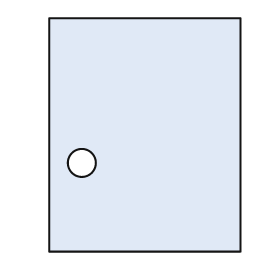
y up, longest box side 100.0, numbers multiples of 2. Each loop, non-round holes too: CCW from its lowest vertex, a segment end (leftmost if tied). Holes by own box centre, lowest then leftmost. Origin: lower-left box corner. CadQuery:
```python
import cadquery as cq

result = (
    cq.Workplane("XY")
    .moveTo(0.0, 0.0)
    .lineTo(82.0, 0.0)
    .lineTo(82.0, 100.0)
    .lineTo(0.0, 100.0)
    .close()
    .moveTo(14.0, 38.0)
    .circle(6.0)
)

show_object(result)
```